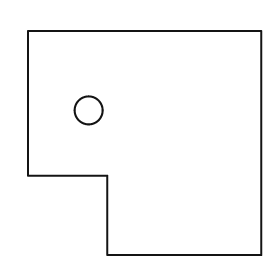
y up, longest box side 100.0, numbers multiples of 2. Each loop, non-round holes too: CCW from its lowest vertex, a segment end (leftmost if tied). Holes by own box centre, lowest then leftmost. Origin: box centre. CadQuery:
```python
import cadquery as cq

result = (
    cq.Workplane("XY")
    .moveTo(-16.0, -48.0)
    .lineTo(50.0, -48.0)
    .lineTo(50.0, 48.0)
    .lineTo(-50.0, 48.0)
    .lineTo(-50.0, -14.0)
    .lineTo(-16.0, -14.0)
    .close()
    .moveTo(-24.0, 14.0)
    .circle(6.0)
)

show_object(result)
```